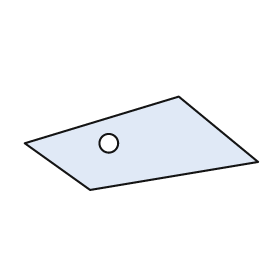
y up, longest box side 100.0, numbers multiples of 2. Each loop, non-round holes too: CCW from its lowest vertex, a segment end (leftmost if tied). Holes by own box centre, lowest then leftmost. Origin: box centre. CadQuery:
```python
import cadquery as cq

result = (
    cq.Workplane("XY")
    .moveTo(-22.0, -20.0)
    .lineTo(50.0, -8.0)
    .lineTo(16.0, 20.0)
    .lineTo(-50.0, 0.0)
    .close()
    .moveTo(-14.0, 0.0)
    .circle(4.0)
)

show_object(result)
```